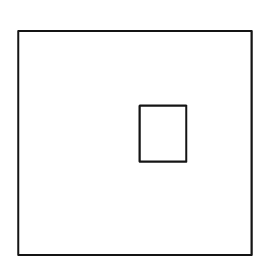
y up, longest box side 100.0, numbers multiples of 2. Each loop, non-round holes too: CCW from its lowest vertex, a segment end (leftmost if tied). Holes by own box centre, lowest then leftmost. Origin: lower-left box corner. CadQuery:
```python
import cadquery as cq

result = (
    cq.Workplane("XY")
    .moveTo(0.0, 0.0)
    .lineTo(100.0, 0.0)
    .lineTo(100.0, 96.0)
    .lineTo(0.0, 96.0)
    .close()
    .moveTo(52.0, 40.0)
    .lineTo(72.0, 40.0)
    .lineTo(72.0, 64.0)
    .lineTo(52.0, 64.0)
    .close()
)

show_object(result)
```